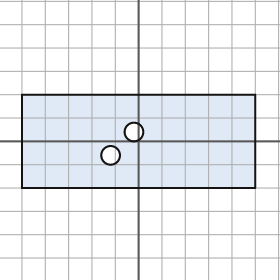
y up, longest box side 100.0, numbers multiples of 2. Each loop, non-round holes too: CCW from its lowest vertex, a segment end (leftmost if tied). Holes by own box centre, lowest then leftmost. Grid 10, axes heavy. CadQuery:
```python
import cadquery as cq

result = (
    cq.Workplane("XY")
    .moveTo(-50.0, -20.0)
    .lineTo(50.0, -20.0)
    .lineTo(50.0, 20.0)
    .lineTo(-50.0, 20.0)
    .close()
    .moveTo(-12.0, -6.0)
    .circle(4.0)
    .moveTo(-2.0, 4.0)
    .circle(4.0)
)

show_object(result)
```